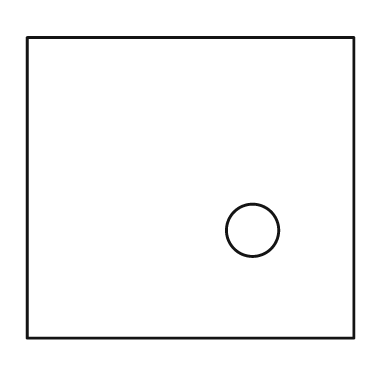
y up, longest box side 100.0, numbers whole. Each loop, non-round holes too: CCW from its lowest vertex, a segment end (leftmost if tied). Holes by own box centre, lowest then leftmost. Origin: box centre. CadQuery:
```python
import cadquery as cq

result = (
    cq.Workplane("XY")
    .moveTo(-50.0, -46.0)
    .lineTo(50.0, -46.0)
    .lineTo(50.0, 46.0)
    .lineTo(-50.0, 46.0)
    .close()
    .moveTo(19.0, -13.0)
    .circle(8.0)
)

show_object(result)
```